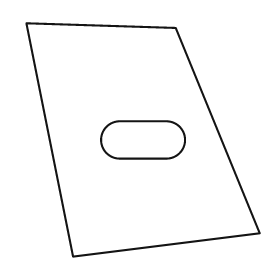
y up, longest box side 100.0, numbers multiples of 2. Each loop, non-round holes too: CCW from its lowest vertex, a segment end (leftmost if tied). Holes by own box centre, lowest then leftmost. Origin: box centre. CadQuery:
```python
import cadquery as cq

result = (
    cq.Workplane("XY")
    .moveTo(-30.0, -50.0)
    .lineTo(50.0, -40.0)
    .lineTo(14.0, 48.0)
    .lineTo(-50.0, 50.0)
    .close()
    .moveTo(-10.0, -8.0)
    .lineTo(10.0, -8.0)
    .threePointArc((18.0, 0.0), (10.0, 8.0))
    .lineTo(-10.0, 8.0)
    .threePointArc((-18.0, 0.0), (-10.0, -8.0))
    .close()
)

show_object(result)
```